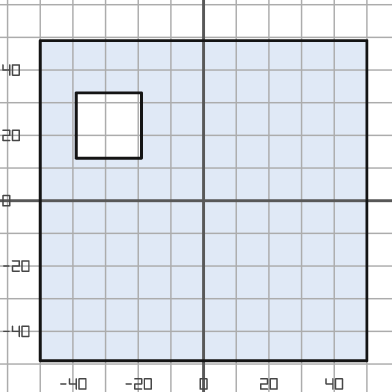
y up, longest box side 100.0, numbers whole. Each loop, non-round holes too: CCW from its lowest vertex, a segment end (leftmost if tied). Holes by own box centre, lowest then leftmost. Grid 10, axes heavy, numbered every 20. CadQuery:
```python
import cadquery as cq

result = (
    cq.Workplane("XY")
    .moveTo(-50.0, -49.0)
    .lineTo(50.0, -49.0)
    .lineTo(50.0, 49.0)
    .lineTo(-50.0, 49.0)
    .close()
    .moveTo(-39.0, 13.0)
    .lineTo(-19.0, 13.0)
    .lineTo(-19.0, 33.0)
    .lineTo(-39.0, 33.0)
    .close()
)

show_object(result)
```